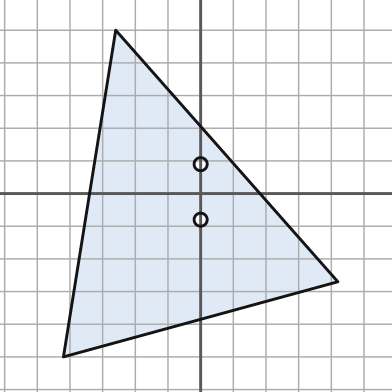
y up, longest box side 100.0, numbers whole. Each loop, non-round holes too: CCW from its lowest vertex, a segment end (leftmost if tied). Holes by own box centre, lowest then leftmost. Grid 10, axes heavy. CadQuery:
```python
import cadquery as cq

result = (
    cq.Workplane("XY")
    .moveTo(-42.0, -50.0)
    .lineTo(42.0, -27.0)
    .lineTo(-26.0, 50.0)
    .close()
    .moveTo(0.0, -8.0)
    .circle(2.0)
    .moveTo(0.0, 9.0)
    .circle(2.0)
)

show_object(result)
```